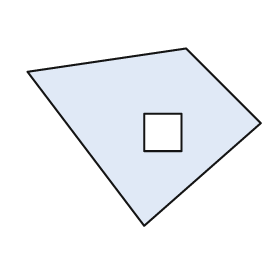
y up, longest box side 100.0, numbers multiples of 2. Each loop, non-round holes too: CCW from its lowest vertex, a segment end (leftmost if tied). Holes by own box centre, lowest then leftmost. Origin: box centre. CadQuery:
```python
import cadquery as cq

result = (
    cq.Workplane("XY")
    .moveTo(0.0, -38.0)
    .lineTo(50.0, 6.0)
    .lineTo(18.0, 38.0)
    .lineTo(-50.0, 28.0)
    .close()
    .moveTo(0.0, -6.0)
    .lineTo(16.0, -6.0)
    .lineTo(16.0, 10.0)
    .lineTo(0.0, 10.0)
    .close()
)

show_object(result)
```